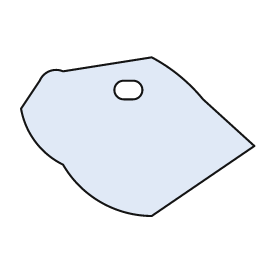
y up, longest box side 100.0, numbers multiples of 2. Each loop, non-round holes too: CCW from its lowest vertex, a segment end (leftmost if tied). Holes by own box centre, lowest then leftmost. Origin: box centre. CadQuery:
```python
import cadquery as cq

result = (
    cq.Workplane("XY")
    .moveTo(6.0, -34.0)
    .lineTo(50.0, -4.0)
    .lineTo(28.0, 16.0)
    .threePointArc((18.0, 26.0), (6.0, 34.0))
    .lineTo(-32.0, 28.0)
    .threePointArc((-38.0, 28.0), (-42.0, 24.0))
    .lineTo(-50.0, 12.0)
    .threePointArc((-44.0, -2.0), (-32.0, -12.0))
    .threePointArc((-16.0, -28.0), (6.0, -34.0))
    .close()
    .moveTo(-6.0, 16.0)
    .lineTo(-2.0, 16.0)
    .threePointArc((2.0, 20.0), (-2.0, 24.0))
    .lineTo(-6.0, 24.0)
    .threePointArc((-10.0, 20.0), (-6.0, 16.0))
    .close()
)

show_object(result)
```